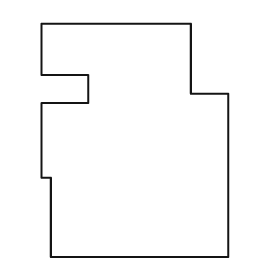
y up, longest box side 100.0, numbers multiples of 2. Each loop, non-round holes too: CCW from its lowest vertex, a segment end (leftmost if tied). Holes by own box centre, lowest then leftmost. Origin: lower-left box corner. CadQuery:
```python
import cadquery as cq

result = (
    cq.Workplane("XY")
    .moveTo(4.0, 0.0)
    .lineTo(80.0, 0.0)
    .lineTo(80.0, 70.0)
    .lineTo(64.0, 70.0)
    .lineTo(64.0, 100.0)
    .lineTo(0.0, 100.0)
    .lineTo(0.0, 78.0)
    .lineTo(20.0, 78.0)
    .lineTo(20.0, 66.0)
    .lineTo(0.0, 66.0)
    .lineTo(0.0, 34.0)
    .lineTo(4.0, 34.0)
    .close()
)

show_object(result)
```